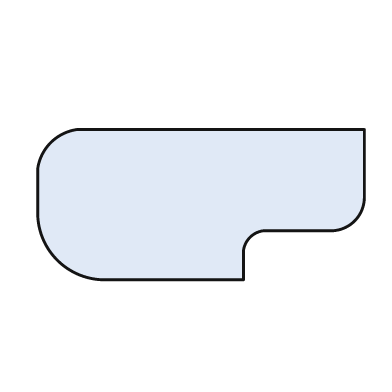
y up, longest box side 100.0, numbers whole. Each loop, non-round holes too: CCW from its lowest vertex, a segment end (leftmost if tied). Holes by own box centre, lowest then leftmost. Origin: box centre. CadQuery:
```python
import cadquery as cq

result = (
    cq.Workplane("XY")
    .moveTo(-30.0, -23.0)
    .lineTo(13.0, -23.0)
    .lineTo(13.0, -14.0)
    .threePointArc((15.0, -10.0), (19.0, -8.0))
    .lineTo(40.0, -8.0)
    .threePointArc((47.0, -5.0), (50.0, 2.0))
    .lineTo(50.0, 23.0)
    .lineTo(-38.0, 23.0)
    .threePointArc((-46.0, 19.0), (-50.0, 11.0))
    .lineTo(-50.0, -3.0)
    .threePointArc((-44.0, -17.0), (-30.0, -23.0))
    .close()
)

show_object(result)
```